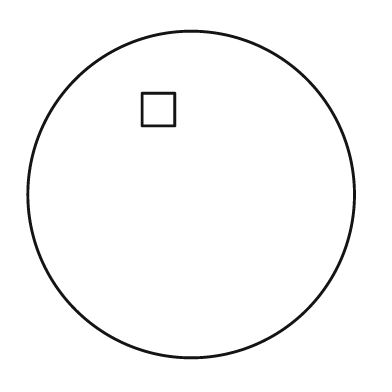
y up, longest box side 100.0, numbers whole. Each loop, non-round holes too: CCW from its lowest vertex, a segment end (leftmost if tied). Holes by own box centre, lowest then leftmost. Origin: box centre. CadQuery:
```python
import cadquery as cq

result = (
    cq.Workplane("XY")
    .moveTo(0.0, 0.0)
    .circle(50.0)
    .moveTo(-15.0, 21.0)
    .lineTo(-5.0, 21.0)
    .lineTo(-5.0, 31.0)
    .lineTo(-15.0, 31.0)
    .close()
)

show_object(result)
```